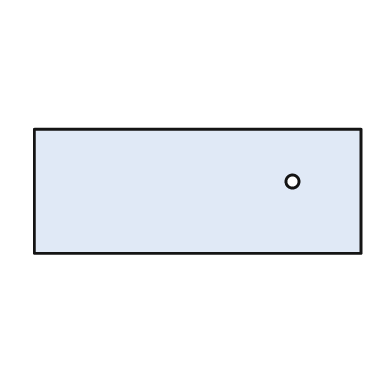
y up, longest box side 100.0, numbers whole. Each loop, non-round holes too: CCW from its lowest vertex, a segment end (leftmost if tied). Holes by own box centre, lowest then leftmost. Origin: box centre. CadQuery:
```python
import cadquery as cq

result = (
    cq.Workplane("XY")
    .moveTo(-50.0, -19.0)
    .lineTo(50.0, -19.0)
    .lineTo(50.0, 19.0)
    .lineTo(-50.0, 19.0)
    .close()
    .moveTo(29.0, 3.0)
    .circle(2.0)
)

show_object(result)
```